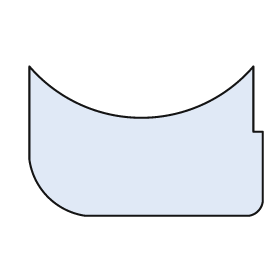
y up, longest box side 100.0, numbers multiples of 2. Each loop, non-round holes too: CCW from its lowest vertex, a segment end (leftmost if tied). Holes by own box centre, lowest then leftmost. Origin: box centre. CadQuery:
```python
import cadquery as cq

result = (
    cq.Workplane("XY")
    .moveTo(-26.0, -32.0)
    .lineTo(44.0, -32.0)
    .threePointArc((48.0, -30.0), (50.0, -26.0))
    .lineTo(50.0, 4.0)
    .lineTo(46.0, 4.0)
    .lineTo(46.0, 32.0)
    .threePointArc((-2.0, 10.0), (-50.0, 32.0))
    .lineTo(-50.0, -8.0)
    .threePointArc((-42.0, -24.0), (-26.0, -32.0))
    .close()
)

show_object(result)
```